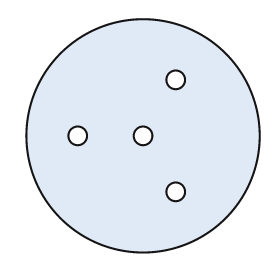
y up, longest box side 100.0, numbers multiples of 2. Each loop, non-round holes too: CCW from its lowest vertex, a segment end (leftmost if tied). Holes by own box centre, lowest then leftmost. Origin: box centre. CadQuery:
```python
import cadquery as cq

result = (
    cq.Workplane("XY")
    .moveTo(0.0, 0.0)
    .circle(50.0)
    .moveTo(14.0, -24.0)
    .circle(4.0)
    .moveTo(-28.0, 0.0)
    .circle(4.0)
    .moveTo(0.0, 0.0)
    .circle(4.0)
    .moveTo(14.0, 24.0)
    .circle(4.0)
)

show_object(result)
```